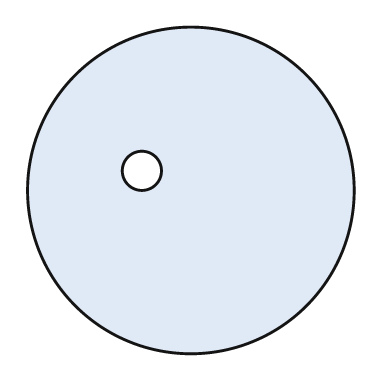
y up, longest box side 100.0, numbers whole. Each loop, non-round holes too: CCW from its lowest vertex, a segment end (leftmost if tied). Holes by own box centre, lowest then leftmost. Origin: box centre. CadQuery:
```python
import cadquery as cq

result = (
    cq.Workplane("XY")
    .moveTo(0.0, 0.0)
    .circle(50.0)
    .moveTo(-15.0, 6.0)
    .circle(6.0)
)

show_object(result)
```